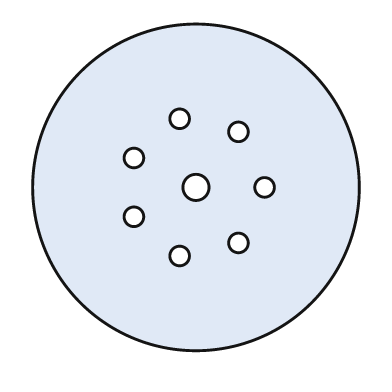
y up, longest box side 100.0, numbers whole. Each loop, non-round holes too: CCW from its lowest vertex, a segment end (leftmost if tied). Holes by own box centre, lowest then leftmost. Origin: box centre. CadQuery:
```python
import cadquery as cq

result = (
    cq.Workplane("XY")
    .moveTo(0.0, 0.0)
    .circle(50.0)
    .moveTo(-5.0, -21.0)
    .circle(3.0)
    .moveTo(13.0, -17.0)
    .circle(3.0)
    .moveTo(-19.0, -9.0)
    .circle(3.0)
    .moveTo(0.0, 0.0)
    .circle(4.0)
    .moveTo(21.0, 0.0)
    .circle(3.0)
    .moveTo(-19.0, 9.0)
    .circle(3.0)
    .moveTo(13.0, 17.0)
    .circle(3.0)
    .moveTo(-5.0, 21.0)
    .circle(3.0)
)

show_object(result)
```